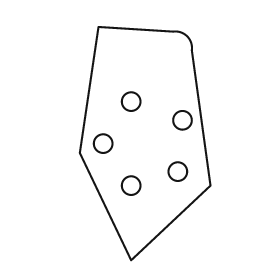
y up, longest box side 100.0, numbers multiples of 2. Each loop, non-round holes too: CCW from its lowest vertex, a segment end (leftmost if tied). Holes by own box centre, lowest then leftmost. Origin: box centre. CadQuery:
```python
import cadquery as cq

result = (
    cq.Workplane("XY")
    .moveTo(-6.0, -50.0)
    .lineTo(28.0, -18.0)
    .lineTo(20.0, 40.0)
    .threePointArc((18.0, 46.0), (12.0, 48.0))
    .lineTo(-20.0, 50.0)
    .lineTo(-28.0, -4.0)
    .close()
    .moveTo(-6.0, -18.0)
    .circle(4.0)
    .moveTo(14.0, -12.0)
    .circle(4.0)
    .moveTo(-18.0, 0.0)
    .circle(4.0)
    .moveTo(16.0, 10.0)
    .circle(4.0)
    .moveTo(-6.0, 18.0)
    .circle(4.0)
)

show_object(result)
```